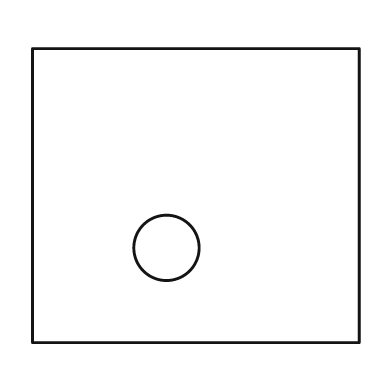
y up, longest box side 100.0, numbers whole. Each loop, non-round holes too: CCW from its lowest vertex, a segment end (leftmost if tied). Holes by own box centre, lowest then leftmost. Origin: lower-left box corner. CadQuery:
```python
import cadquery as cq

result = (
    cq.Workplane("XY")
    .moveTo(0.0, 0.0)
    .lineTo(100.0, 0.0)
    .lineTo(100.0, 90.0)
    .lineTo(0.0, 90.0)
    .close()
    .moveTo(41.0, 29.0)
    .circle(10.0)
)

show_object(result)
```